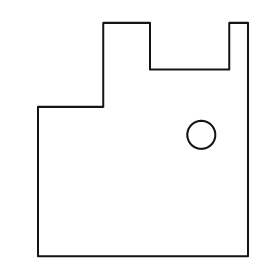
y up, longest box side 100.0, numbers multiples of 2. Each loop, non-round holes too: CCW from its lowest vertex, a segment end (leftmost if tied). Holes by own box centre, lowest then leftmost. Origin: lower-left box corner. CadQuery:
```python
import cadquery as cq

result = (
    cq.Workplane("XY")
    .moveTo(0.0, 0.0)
    .lineTo(90.0, 0.0)
    .lineTo(90.0, 100.0)
    .lineTo(82.0, 100.0)
    .lineTo(82.0, 80.0)
    .lineTo(48.0, 80.0)
    .lineTo(48.0, 100.0)
    .lineTo(28.0, 100.0)
    .lineTo(28.0, 64.0)
    .lineTo(0.0, 64.0)
    .close()
    .moveTo(70.0, 52.0)
    .circle(6.0)
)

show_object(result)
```